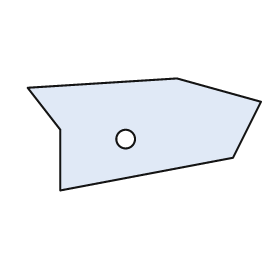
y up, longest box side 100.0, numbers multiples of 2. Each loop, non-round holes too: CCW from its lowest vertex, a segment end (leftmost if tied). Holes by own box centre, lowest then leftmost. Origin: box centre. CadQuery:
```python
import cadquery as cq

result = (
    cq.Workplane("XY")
    .moveTo(-36.0, -24.0)
    .lineTo(38.0, -10.0)
    .lineTo(50.0, 14.0)
    .lineTo(14.0, 24.0)
    .lineTo(-50.0, 20.0)
    .lineTo(-36.0, 2.0)
    .close()
    .moveTo(-8.0, -2.0)
    .circle(4.0)
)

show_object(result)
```